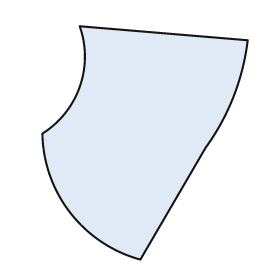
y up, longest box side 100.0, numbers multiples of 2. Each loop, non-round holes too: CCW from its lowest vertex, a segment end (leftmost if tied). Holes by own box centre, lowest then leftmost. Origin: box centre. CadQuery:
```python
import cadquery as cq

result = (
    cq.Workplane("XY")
    .moveTo(-2.0, -50.0)
    .lineTo(26.0, -2.0)
    .threePointArc((38.0, 20.0), (44.0, 44.0))
    .lineTo(-28.0, 50.0)
    .threePointArc((-28.0, 24.0), (-44.0, 4.0))
    .threePointArc((-32.0, -30.0), (-2.0, -50.0))
    .close()
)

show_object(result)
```